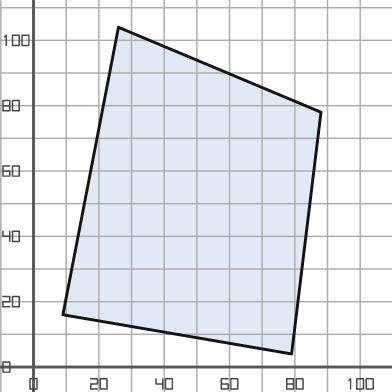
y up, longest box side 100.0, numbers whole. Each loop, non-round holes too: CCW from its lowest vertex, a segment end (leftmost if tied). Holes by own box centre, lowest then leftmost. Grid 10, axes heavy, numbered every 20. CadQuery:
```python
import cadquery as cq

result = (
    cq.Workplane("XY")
    .moveTo(79.0, 4.0)
    .lineTo(88.0, 78.0)
    .lineTo(26.0, 104.0)
    .lineTo(9.0, 16.0)
    .close()
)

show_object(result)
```